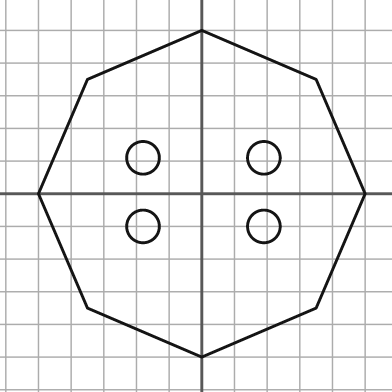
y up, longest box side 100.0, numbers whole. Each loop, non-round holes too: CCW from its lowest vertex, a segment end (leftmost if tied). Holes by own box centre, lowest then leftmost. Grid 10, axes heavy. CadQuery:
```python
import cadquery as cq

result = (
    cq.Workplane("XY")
    .moveTo(0.0, -50.0)
    .lineTo(35.0, -35.0)
    .lineTo(50.0, 0.0)
    .lineTo(35.0, 35.0)
    .lineTo(0.0, 50.0)
    .lineTo(-35.0, 35.0)
    .lineTo(-50.0, 0.0)
    .lineTo(-35.0, -35.0)
    .close()
    .moveTo(-18.0, -10.0)
    .circle(5.0)
    .moveTo(19.0, -10.0)
    .circle(5.0)
    .moveTo(-18.0, 11.0)
    .circle(5.0)
    .moveTo(19.0, 11.0)
    .circle(5.0)
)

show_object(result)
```